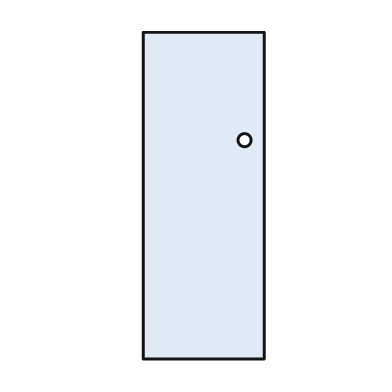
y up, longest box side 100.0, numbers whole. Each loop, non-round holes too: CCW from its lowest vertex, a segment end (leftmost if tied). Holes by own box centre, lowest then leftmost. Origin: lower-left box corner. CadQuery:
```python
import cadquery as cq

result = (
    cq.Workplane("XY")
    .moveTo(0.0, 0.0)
    .lineTo(37.0, 0.0)
    .lineTo(37.0, 100.0)
    .lineTo(0.0, 100.0)
    .close()
    .moveTo(31.0, 67.0)
    .circle(2.0)
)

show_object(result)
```